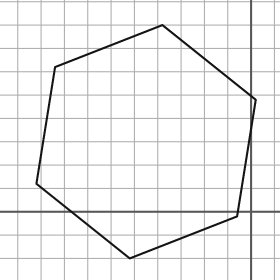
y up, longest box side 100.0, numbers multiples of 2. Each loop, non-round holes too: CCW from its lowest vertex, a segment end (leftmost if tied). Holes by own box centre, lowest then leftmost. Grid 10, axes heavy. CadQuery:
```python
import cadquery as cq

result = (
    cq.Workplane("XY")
    .moveTo(-52.0, -20.0)
    .lineTo(-6.0, -2.0)
    .lineTo(2.0, 48.0)
    .lineTo(-38.0, 80.0)
    .lineTo(-84.0, 62.0)
    .lineTo(-92.0, 12.0)
    .close()
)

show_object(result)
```